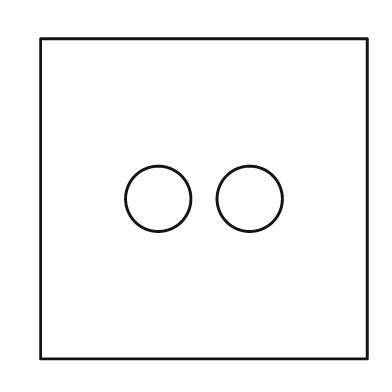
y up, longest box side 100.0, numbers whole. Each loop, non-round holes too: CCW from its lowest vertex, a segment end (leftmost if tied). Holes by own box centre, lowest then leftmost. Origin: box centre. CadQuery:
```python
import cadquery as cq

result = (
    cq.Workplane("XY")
    .moveTo(-50.0, -49.0)
    .lineTo(50.0, -49.0)
    .lineTo(50.0, 49.0)
    .lineTo(-50.0, 49.0)
    .close()
    .moveTo(-14.0, 0.0)
    .circle(10.0)
    .moveTo(14.0, 0.0)
    .circle(10.0)
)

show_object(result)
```